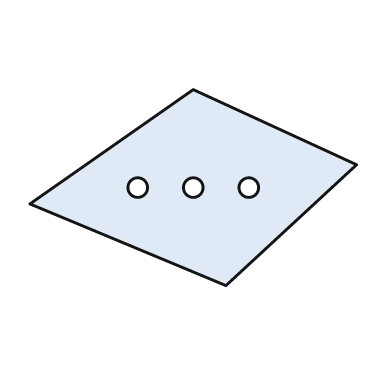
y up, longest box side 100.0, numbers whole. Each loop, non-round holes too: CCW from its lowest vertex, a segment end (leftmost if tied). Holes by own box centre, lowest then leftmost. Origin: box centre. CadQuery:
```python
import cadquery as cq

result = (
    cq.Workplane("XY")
    .moveTo(10.0, -30.0)
    .lineTo(50.0, 7.0)
    .lineTo(0.0, 30.0)
    .lineTo(-50.0, -5.0)
    .close()
    .moveTo(-17.0, 0.0)
    .circle(3.0)
    .moveTo(0.0, 0.0)
    .circle(3.0)
    .moveTo(17.0, 0.0)
    .circle(3.0)
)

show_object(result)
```